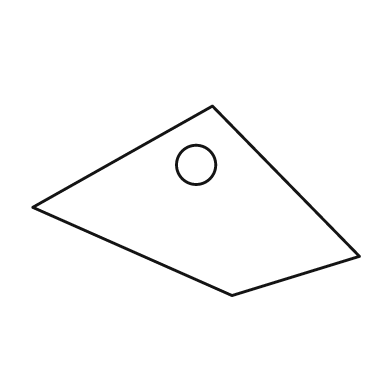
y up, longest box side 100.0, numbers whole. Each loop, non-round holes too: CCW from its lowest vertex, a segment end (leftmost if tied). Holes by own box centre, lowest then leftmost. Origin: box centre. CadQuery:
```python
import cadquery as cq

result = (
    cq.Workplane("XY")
    .moveTo(11.0, -29.0)
    .lineTo(50.0, -17.0)
    .lineTo(5.0, 29.0)
    .lineTo(-50.0, -2.0)
    .close()
    .moveTo(0.0, 11.0)
    .circle(6.0)
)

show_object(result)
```